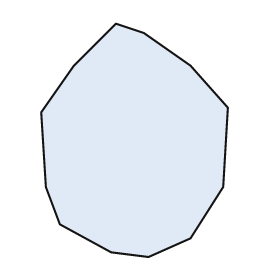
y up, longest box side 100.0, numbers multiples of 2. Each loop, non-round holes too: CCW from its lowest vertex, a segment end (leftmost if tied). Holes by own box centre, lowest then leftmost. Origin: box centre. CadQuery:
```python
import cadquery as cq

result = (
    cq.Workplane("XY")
    .moveTo(6.0, -50.0)
    .lineTo(24.0, -42.0)
    .lineTo(38.0, -20.0)
    .lineTo(40.0, 14.0)
    .lineTo(24.0, 32.0)
    .lineTo(4.0, 46.0)
    .lineTo(-8.0, 50.0)
    .lineTo(-26.0, 32.0)
    .lineTo(-40.0, 12.0)
    .lineTo(-38.0, -20.0)
    .lineTo(-32.0, -36.0)
    .lineTo(-10.0, -48.0)
    .close()
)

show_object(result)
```